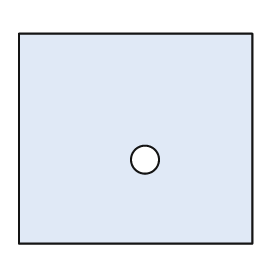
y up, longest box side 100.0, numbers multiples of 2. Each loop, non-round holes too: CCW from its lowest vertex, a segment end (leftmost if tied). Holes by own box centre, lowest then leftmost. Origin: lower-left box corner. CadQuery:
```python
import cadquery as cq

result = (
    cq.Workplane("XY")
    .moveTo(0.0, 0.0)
    .lineTo(100.0, 0.0)
    .lineTo(100.0, 90.0)
    .lineTo(0.0, 90.0)
    .close()
    .moveTo(54.0, 36.0)
    .circle(6.0)
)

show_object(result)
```